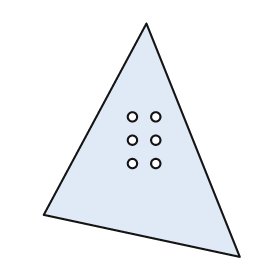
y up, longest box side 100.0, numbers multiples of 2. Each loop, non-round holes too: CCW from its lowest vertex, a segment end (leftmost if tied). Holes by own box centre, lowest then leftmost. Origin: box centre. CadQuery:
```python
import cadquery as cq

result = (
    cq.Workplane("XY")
    .moveTo(42.0, -50.0)
    .lineTo(2.0, 50.0)
    .lineTo(-42.0, -32.0)
    .close()
    .moveTo(-4.0, -10.0)
    .circle(2.0)
    .moveTo(6.0, -10.0)
    .circle(2.0)
    .moveTo(-4.0, 0.0)
    .circle(2.0)
    .moveTo(6.0, 0.0)
    .circle(2.0)
    .moveTo(-4.0, 10.0)
    .circle(2.0)
    .moveTo(6.0, 10.0)
    .circle(2.0)
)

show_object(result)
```